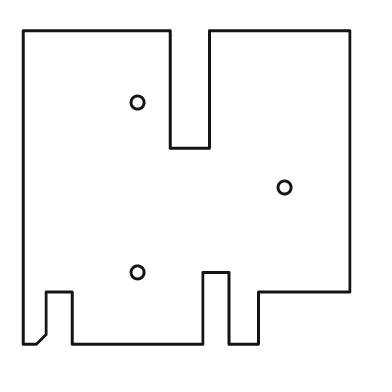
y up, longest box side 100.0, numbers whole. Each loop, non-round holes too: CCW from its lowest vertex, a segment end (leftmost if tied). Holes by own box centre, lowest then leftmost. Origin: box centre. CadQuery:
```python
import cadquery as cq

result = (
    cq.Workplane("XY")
    .moveTo(-50.0, -48.0)
    .lineTo(-46.0, -48.0)
    .lineTo(-43.0, -45.0)
    .lineTo(-43.0, -32.0)
    .lineTo(-35.0, -32.0)
    .lineTo(-35.0, -48.0)
    .lineTo(5.0, -48.0)
    .lineTo(5.0, -26.0)
    .lineTo(13.0, -26.0)
    .lineTo(13.0, -48.0)
    .lineTo(22.0, -48.0)
    .lineTo(22.0, -32.0)
    .lineTo(50.0, -32.0)
    .lineTo(50.0, 48.0)
    .lineTo(7.0, 48.0)
    .lineTo(7.0, 12.0)
    .lineTo(-5.0, 12.0)
    .lineTo(-5.0, 48.0)
    .lineTo(-50.0, 48.0)
    .close()
    .moveTo(-15.0, -26.0)
    .circle(2.0)
    .moveTo(30.0, 0.0)
    .circle(2.0)
    .moveTo(-15.0, 26.0)
    .circle(2.0)
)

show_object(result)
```